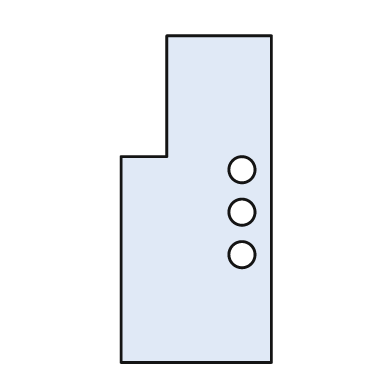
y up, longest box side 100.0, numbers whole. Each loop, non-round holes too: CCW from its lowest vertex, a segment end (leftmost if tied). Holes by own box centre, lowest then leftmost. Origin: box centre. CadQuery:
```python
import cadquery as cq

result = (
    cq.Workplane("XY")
    .moveTo(-23.0, -50.0)
    .lineTo(23.0, -50.0)
    .lineTo(23.0, 50.0)
    .lineTo(-9.0, 50.0)
    .lineTo(-9.0, 13.0)
    .lineTo(-23.0, 13.0)
    .close()
    .moveTo(14.0, -17.0)
    .circle(4.0)
    .moveTo(14.0, -4.0)
    .circle(4.0)
    .moveTo(14.0, 9.0)
    .circle(4.0)
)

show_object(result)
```